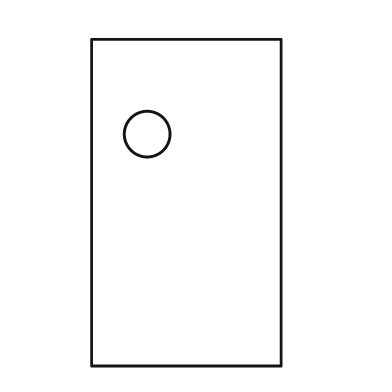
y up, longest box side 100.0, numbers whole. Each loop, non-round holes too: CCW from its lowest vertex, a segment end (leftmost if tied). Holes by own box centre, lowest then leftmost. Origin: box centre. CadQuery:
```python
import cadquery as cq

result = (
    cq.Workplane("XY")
    .moveTo(-29.0, -50.0)
    .lineTo(29.0, -50.0)
    .lineTo(29.0, 50.0)
    .lineTo(-29.0, 50.0)
    .close()
    .moveTo(-12.0, 21.0)
    .circle(7.0)
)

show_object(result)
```